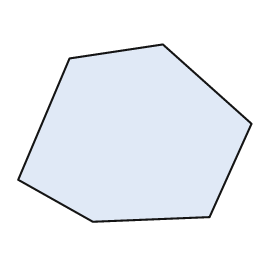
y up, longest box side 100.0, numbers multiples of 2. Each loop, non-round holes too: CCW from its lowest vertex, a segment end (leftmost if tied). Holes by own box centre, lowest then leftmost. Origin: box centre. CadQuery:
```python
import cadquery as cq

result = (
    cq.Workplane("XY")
    .moveTo(-18.0, -38.0)
    .lineTo(32.0, -36.0)
    .lineTo(50.0, 4.0)
    .lineTo(12.0, 38.0)
    .lineTo(-28.0, 32.0)
    .lineTo(-50.0, -20.0)
    .close()
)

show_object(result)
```